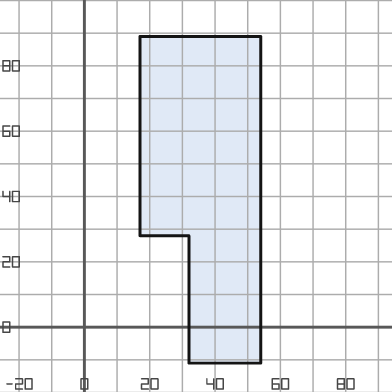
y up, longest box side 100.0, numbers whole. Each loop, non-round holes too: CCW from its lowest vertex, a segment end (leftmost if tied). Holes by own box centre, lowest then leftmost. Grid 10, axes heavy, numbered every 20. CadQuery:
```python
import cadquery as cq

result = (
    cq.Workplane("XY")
    .moveTo(32.0, -11.0)
    .lineTo(54.0, -11.0)
    .lineTo(54.0, 89.0)
    .lineTo(17.0, 89.0)
    .lineTo(17.0, 28.0)
    .lineTo(32.0, 28.0)
    .close()
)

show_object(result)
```